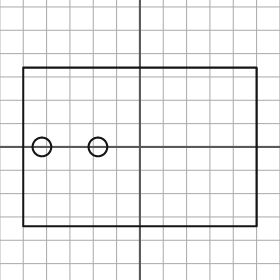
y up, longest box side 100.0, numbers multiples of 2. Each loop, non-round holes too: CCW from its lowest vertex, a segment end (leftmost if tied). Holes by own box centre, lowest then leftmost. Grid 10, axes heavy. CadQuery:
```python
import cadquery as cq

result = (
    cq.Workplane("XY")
    .moveTo(-50.0, -34.0)
    .lineTo(50.0, -34.0)
    .lineTo(50.0, 34.0)
    .lineTo(-50.0, 34.0)
    .close()
    .moveTo(-42.0, 0.0)
    .circle(4.0)
    .moveTo(-18.0, 0.0)
    .circle(4.0)
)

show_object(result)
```